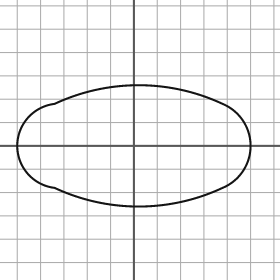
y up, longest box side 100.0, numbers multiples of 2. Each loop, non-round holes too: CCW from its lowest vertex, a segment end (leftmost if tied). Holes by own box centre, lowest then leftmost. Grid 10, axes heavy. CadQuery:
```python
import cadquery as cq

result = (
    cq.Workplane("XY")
    .moveTo(-34.0, -18.0)
    .threePointArc((2.0, -26.0), (38.0, -18.0))
    .threePointArc((50.0, 0.0), (38.0, 18.0))
    .threePointArc((2.0, 26.0), (-34.0, 18.0))
    .threePointArc((-50.0, 0.0), (-34.0, -18.0))
    .close()
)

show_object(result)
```